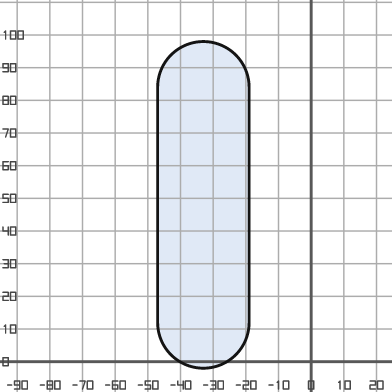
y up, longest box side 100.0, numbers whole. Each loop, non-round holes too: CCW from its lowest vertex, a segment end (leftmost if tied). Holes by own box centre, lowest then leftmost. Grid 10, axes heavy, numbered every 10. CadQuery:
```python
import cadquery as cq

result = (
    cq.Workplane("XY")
    .moveTo(-47.0, 12.0)
    .threePointArc((-33.0, -2.0), (-19.0, 12.0))
    .lineTo(-19.0, 84.0)
    .threePointArc((-33.0, 98.0), (-47.0, 84.0))
    .close()
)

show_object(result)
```